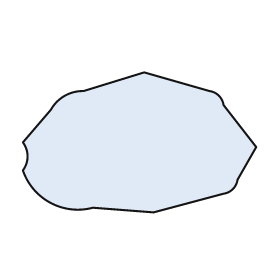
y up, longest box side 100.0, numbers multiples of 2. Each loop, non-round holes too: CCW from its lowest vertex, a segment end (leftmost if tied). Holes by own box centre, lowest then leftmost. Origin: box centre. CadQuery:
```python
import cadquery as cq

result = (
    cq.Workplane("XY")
    .moveTo(6.0, -30.0)
    .lineTo(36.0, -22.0)
    .threePointArc((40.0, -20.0), (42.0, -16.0))
    .lineTo(50.0, -2.0)
    .lineTo(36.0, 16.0)
    .threePointArc((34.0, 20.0), (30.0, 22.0))
    .lineTo(2.0, 30.0)
    .lineTo(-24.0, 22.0)
    .threePointArc((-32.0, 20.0), (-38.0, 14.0))
    .lineTo(-50.0, 0.0)
    .threePointArc((-48.0, -6.0), (-50.0, -12.0))
    .threePointArc((-38.0, -26.0), (-20.0, -28.0))
    .close()
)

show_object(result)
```